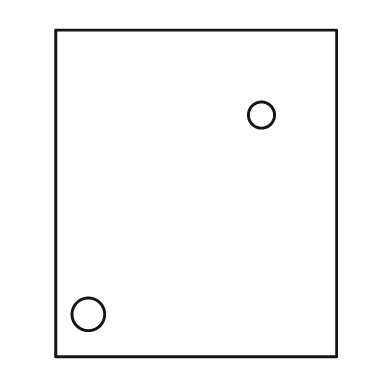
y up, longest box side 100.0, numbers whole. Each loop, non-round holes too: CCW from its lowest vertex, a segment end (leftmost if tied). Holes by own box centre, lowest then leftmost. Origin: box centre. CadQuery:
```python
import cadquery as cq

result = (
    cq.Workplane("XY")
    .moveTo(-43.0, -50.0)
    .lineTo(43.0, -50.0)
    .lineTo(43.0, 50.0)
    .lineTo(-43.0, 50.0)
    .close()
    .moveTo(-33.0, -37.0)
    .circle(5.0)
    .moveTo(20.0, 24.0)
    .circle(4.0)
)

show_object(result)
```